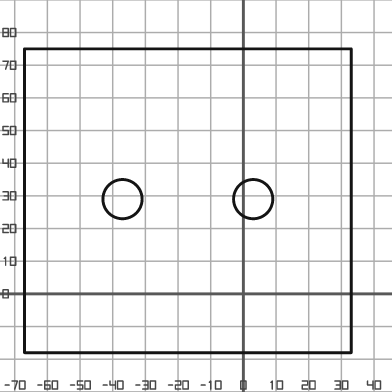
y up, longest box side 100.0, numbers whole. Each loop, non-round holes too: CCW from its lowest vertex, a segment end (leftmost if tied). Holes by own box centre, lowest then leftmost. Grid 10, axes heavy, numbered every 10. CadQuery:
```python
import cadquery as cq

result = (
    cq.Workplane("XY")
    .moveTo(-67.0, -18.0)
    .lineTo(33.0, -18.0)
    .lineTo(33.0, 75.0)
    .lineTo(-67.0, 75.0)
    .close()
    .moveTo(-37.0, 29.0)
    .circle(6.0)
    .moveTo(3.0, 29.0)
    .circle(6.0)
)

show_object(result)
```